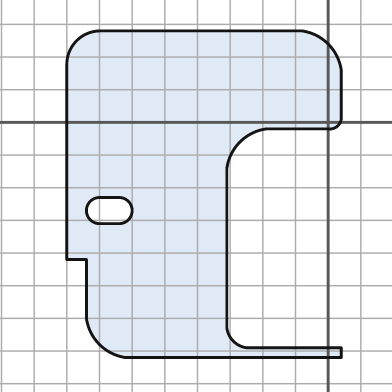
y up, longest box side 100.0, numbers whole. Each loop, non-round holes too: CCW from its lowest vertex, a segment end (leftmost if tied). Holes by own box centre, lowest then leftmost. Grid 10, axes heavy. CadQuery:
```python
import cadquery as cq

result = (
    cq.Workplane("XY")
    .moveTo(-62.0, -72.0)
    .lineTo(4.0, -72.0)
    .lineTo(4.0, -69.0)
    .lineTo(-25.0, -69.0)
    .threePointArc((-29.0, -67.0), (-31.0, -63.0))
    .lineTo(-31.0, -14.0)
    .threePointArc((-27.0, -6.0), (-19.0, -2.0))
    .lineTo(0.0, -2.0)
    .threePointArc((3.0, -1.0), (4.0, 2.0))
    .lineTo(4.0, 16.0)
    .threePointArc((0.0, 24.0), (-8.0, 28.0))
    .lineTo(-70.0, 28.0)
    .threePointArc((-77.0, 25.0), (-80.0, 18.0))
    .lineTo(-80.0, -42.0)
    .lineTo(-74.0, -42.0)
    .lineTo(-74.0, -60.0)
    .threePointArc((-70.0, -68.0), (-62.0, -72.0))
    .close()
    .moveTo(-70.0, -31.0)
    .lineTo(-64.0, -31.0)
    .threePointArc((-60.0, -27.0), (-64.0, -23.0))
    .lineTo(-70.0, -23.0)
    .threePointArc((-74.0, -27.0), (-70.0, -31.0))
    .close()
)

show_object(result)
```